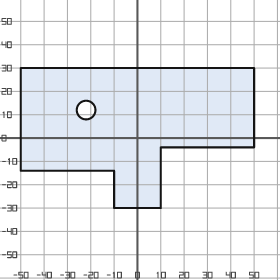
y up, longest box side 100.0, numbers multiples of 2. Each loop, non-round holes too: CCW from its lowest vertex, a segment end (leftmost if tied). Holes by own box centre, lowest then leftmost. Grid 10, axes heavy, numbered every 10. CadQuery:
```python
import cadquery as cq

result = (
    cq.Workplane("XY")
    .moveTo(-10.0, -30.0)
    .lineTo(10.0, -30.0)
    .lineTo(10.0, -4.0)
    .lineTo(50.0, -4.0)
    .lineTo(50.0, 30.0)
    .lineTo(-50.0, 30.0)
    .lineTo(-50.0, -14.0)
    .lineTo(-10.0, -14.0)
    .close()
    .moveTo(-22.0, 12.0)
    .circle(4.0)
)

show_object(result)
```